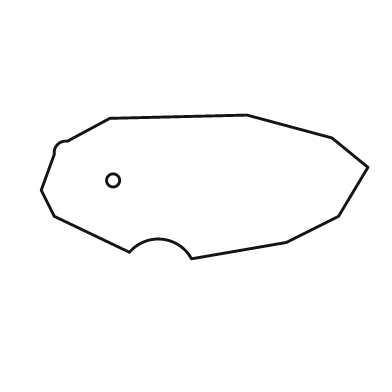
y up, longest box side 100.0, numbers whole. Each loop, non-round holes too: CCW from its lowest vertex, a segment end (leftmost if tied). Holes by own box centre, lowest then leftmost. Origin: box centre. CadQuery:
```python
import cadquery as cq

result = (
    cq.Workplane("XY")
    .moveTo(-4.0, -22.0)
    .lineTo(25.0, -17.0)
    .lineTo(41.0, -9.0)
    .lineTo(50.0, 6.0)
    .lineTo(39.0, 15.0)
    .lineTo(13.0, 22.0)
    .lineTo(-29.0, 21.0)
    .lineTo(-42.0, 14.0)
    .threePointArc((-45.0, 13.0), (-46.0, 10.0))
    .lineTo(-50.0, -1.0)
    .lineTo(-46.0, -9.0)
    .lineTo(-23.0, -20.0)
    .threePointArc((-13.0, -16.0), (-4.0, -22.0))
    .close()
    .moveTo(-28.0, 2.0)
    .circle(2.0)
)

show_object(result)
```